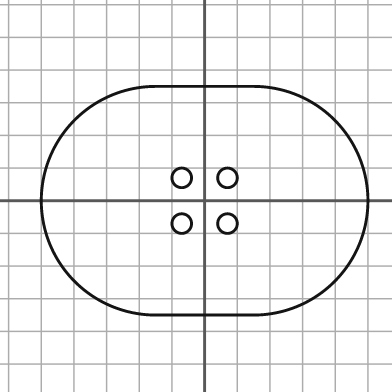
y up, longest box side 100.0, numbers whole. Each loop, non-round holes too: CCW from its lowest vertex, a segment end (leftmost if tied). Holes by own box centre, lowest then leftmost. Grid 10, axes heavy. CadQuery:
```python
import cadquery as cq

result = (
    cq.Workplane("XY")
    .moveTo(-15.0, -35.0)
    .lineTo(15.0, -35.0)
    .threePointArc((50.0, 0.0), (15.0, 35.0))
    .lineTo(-15.0, 35.0)
    .threePointArc((-50.0, 0.0), (-15.0, -35.0))
    .close()
    .moveTo(-7.0, -7.0)
    .circle(3.0)
    .moveTo(7.0, -7.0)
    .circle(3.0)
    .moveTo(-7.0, 7.0)
    .circle(3.0)
    .moveTo(7.0, 7.0)
    .circle(3.0)
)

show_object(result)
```